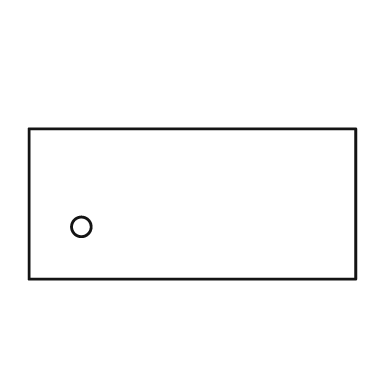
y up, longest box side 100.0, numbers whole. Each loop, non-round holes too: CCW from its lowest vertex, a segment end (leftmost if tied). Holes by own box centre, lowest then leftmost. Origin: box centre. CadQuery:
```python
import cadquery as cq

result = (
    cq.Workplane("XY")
    .moveTo(-50.0, -23.0)
    .lineTo(50.0, -23.0)
    .lineTo(50.0, 23.0)
    .lineTo(-50.0, 23.0)
    .close()
    .moveTo(-34.0, -7.0)
    .circle(3.0)
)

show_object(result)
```